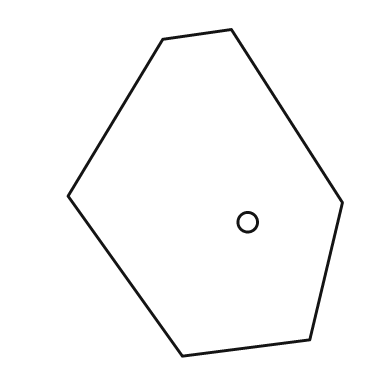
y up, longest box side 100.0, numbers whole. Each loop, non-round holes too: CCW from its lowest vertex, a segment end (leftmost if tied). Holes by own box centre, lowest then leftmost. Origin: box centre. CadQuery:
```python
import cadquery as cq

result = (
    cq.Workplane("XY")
    .moveTo(-7.0, -50.0)
    .lineTo(32.0, -45.0)
    .lineTo(42.0, -3.0)
    .lineTo(8.0, 50.0)
    .lineTo(-13.0, 47.0)
    .lineTo(-42.0, -1.0)
    .close()
    .moveTo(13.0, -9.0)
    .circle(3.0)
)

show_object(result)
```